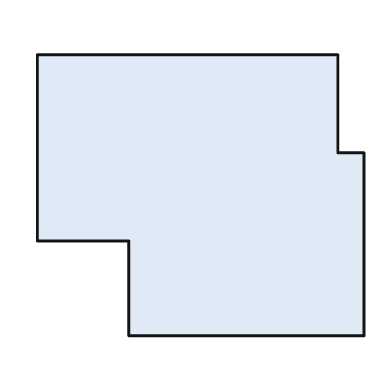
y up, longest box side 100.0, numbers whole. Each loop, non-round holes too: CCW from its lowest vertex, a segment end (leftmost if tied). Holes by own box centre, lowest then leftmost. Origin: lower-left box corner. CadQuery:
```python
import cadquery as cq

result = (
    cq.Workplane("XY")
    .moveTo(28.0, 0.0)
    .lineTo(100.0, 0.0)
    .lineTo(100.0, 56.0)
    .lineTo(92.0, 56.0)
    .lineTo(92.0, 86.0)
    .lineTo(0.0, 86.0)
    .lineTo(0.0, 29.0)
    .lineTo(28.0, 29.0)
    .close()
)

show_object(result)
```